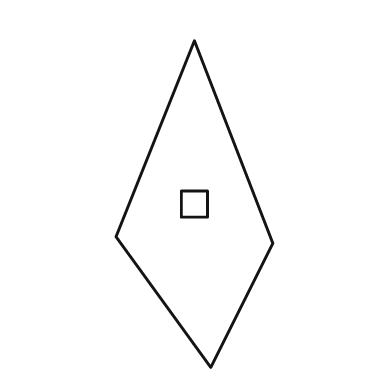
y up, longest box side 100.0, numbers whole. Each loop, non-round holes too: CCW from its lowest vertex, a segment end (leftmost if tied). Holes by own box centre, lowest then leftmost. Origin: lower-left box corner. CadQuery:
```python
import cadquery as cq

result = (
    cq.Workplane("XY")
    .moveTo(29.0, 0.0)
    .lineTo(48.0, 38.0)
    .lineTo(24.0, 100.0)
    .lineTo(0.0, 40.0)
    .close()
    .moveTo(20.0, 46.0)
    .lineTo(28.0, 46.0)
    .lineTo(28.0, 54.0)
    .lineTo(20.0, 54.0)
    .close()
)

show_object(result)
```